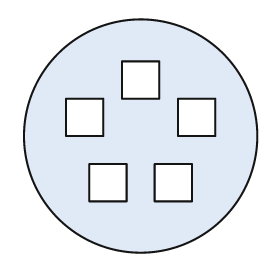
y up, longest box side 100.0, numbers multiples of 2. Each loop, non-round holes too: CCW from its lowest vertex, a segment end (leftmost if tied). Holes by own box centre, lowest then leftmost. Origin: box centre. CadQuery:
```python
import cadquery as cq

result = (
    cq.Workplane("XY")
    .moveTo(0.0, 0.0)
    .circle(50.0)
    .moveTo(-22.0, -28.0)
    .lineTo(-6.0, -28.0)
    .lineTo(-6.0, -12.0)
    .lineTo(-22.0, -12.0)
    .close()
    .moveTo(6.0, -28.0)
    .lineTo(22.0, -28.0)
    .lineTo(22.0, -12.0)
    .lineTo(6.0, -12.0)
    .close()
    .moveTo(-32.0, 0.0)
    .lineTo(-16.0, 0.0)
    .lineTo(-16.0, 16.0)
    .lineTo(-32.0, 16.0)
    .close()
    .moveTo(16.0, 0.0)
    .lineTo(32.0, 0.0)
    .lineTo(32.0, 16.0)
    .lineTo(16.0, 16.0)
    .close()
    .moveTo(-8.0, 16.0)
    .lineTo(8.0, 16.0)
    .lineTo(8.0, 32.0)
    .lineTo(-8.0, 32.0)
    .close()
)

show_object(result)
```